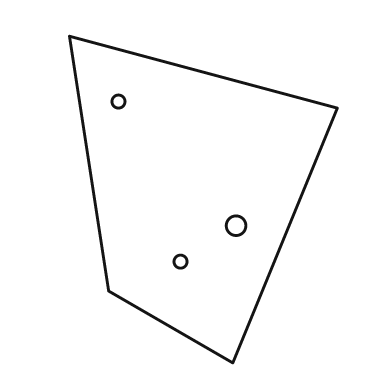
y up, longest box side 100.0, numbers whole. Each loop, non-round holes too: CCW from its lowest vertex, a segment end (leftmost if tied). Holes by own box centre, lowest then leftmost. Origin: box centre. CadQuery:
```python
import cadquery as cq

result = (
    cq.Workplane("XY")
    .moveTo(9.0, -50.0)
    .lineTo(41.0, 28.0)
    .lineTo(-41.0, 50.0)
    .lineTo(-29.0, -28.0)
    .close()
    .moveTo(-7.0, -19.0)
    .circle(2.0)
    .moveTo(10.0, -8.0)
    .circle(3.0)
    .moveTo(-26.0, 30.0)
    .circle(2.0)
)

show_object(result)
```